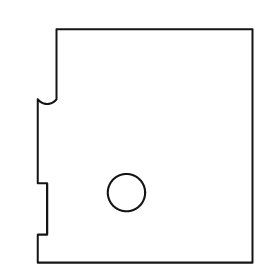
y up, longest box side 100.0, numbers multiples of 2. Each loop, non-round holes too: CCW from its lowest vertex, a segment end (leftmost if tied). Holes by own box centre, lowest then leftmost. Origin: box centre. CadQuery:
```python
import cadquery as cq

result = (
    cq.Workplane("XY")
    .moveTo(-46.0, -50.0)
    .lineTo(46.0, -50.0)
    .lineTo(46.0, 50.0)
    .lineTo(-38.0, 50.0)
    .lineTo(-38.0, 20.0)
    .threePointArc((-42.0, 18.0), (-46.0, 20.0))
    .lineTo(-46.0, -16.0)
    .lineTo(-42.0, -16.0)
    .lineTo(-42.0, -38.0)
    .lineTo(-46.0, -38.0)
    .close()
    .moveTo(-8.0, -20.0)
    .circle(8.0)
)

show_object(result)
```